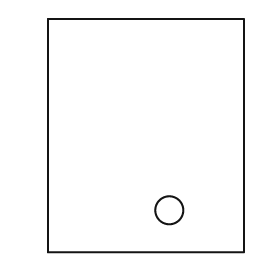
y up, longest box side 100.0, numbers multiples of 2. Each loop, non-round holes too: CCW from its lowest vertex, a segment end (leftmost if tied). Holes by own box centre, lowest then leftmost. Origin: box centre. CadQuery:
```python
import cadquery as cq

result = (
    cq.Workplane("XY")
    .moveTo(-42.0, -50.0)
    .lineTo(42.0, -50.0)
    .lineTo(42.0, 50.0)
    .lineTo(-42.0, 50.0)
    .close()
    .moveTo(10.0, -32.0)
    .circle(6.0)
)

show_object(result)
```